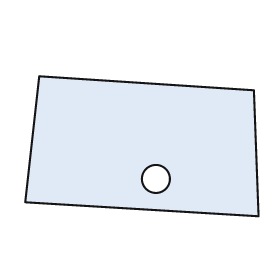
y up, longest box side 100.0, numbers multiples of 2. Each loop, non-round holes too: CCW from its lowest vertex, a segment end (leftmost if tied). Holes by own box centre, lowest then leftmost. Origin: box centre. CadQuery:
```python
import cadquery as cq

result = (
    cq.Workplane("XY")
    .moveTo(50.0, -30.0)
    .lineTo(48.0, 24.0)
    .lineTo(-44.0, 30.0)
    .lineTo(-50.0, -24.0)
    .close()
    .moveTo(6.0, -14.0)
    .circle(6.0)
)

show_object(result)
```